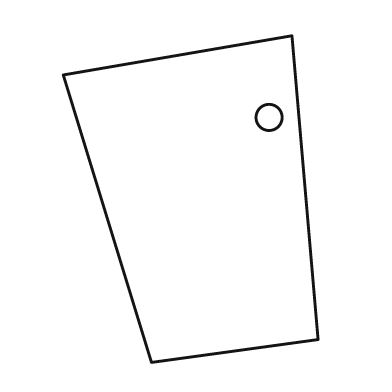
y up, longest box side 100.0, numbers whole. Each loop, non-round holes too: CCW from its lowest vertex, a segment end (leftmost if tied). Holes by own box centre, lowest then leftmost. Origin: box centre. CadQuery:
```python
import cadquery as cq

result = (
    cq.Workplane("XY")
    .moveTo(-12.0, -50.0)
    .lineTo(39.0, -43.0)
    .lineTo(31.0, 50.0)
    .lineTo(-39.0, 38.0)
    .close()
    .moveTo(24.0, 25.0)
    .circle(4.0)
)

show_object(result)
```